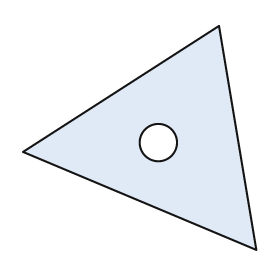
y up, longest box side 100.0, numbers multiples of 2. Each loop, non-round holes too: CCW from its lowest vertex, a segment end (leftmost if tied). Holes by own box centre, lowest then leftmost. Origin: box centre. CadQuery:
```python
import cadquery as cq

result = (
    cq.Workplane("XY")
    .moveTo(50.0, -48.0)
    .lineTo(34.0, 48.0)
    .lineTo(-50.0, -6.0)
    .close()
    .moveTo(8.0, -2.0)
    .circle(8.0)
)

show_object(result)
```